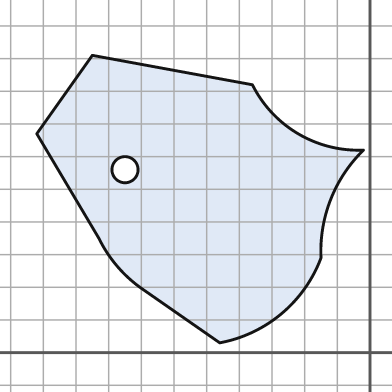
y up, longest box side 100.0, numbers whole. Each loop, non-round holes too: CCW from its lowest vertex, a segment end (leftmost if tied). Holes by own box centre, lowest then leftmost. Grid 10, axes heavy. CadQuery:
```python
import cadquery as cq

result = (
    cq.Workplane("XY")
    .moveTo(-46.0, 3.0)
    .threePointArc((-27.0, 12.0), (-15.0, 29.0))
    .threePointArc((-12.0, 47.0), (-2.0, 62.0))
    .threePointArc((-22.0, 67.0), (-36.0, 82.0))
    .lineTo(-85.0, 91.0)
    .lineTo(-102.0, 67.0)
    .lineTo(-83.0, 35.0)
    .threePointArc((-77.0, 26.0), (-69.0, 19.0))
    .close()
    .moveTo(-75.0, 56.0)
    .circle(4.0)
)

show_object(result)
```